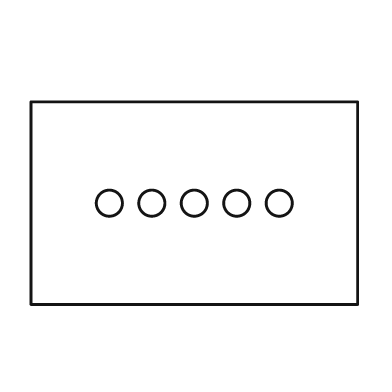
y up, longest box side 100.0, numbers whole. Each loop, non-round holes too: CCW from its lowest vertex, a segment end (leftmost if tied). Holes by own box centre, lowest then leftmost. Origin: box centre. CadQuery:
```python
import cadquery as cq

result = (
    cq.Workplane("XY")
    .moveTo(-50.0, -31.0)
    .lineTo(50.0, -31.0)
    .lineTo(50.0, 31.0)
    .lineTo(-50.0, 31.0)
    .close()
    .moveTo(-26.0, 0.0)
    .circle(4.0)
    .moveTo(-13.0, 0.0)
    .circle(4.0)
    .moveTo(0.0, 0.0)
    .circle(4.0)
    .moveTo(13.0, 0.0)
    .circle(4.0)
    .moveTo(26.0, 0.0)
    .circle(4.0)
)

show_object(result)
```